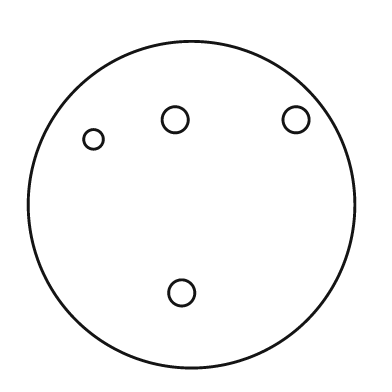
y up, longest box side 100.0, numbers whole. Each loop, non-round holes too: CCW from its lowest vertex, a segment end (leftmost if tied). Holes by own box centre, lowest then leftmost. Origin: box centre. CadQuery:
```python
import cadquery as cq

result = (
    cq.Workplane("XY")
    .moveTo(0.0, 0.0)
    .circle(50.0)
    .moveTo(-3.0, -27.0)
    .circle(4.0)
    .moveTo(-30.0, 20.0)
    .circle(3.0)
    .moveTo(-5.0, 26.0)
    .circle(4.0)
    .moveTo(32.0, 26.0)
    .circle(4.0)
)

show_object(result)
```